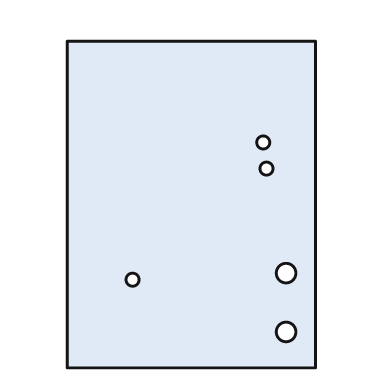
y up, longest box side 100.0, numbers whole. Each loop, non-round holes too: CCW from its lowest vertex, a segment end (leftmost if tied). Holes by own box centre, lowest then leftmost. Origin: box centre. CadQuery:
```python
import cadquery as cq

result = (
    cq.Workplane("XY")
    .moveTo(-38.0, -50.0)
    .lineTo(38.0, -50.0)
    .lineTo(38.0, 50.0)
    .lineTo(-38.0, 50.0)
    .close()
    .moveTo(29.0, -39.0)
    .circle(3.0)
    .moveTo(-18.0, -23.0)
    .circle(2.0)
    .moveTo(29.0, -21.0)
    .circle(3.0)
    .moveTo(23.0, 11.0)
    .circle(2.0)
    .moveTo(22.0, 19.0)
    .circle(2.0)
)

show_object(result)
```